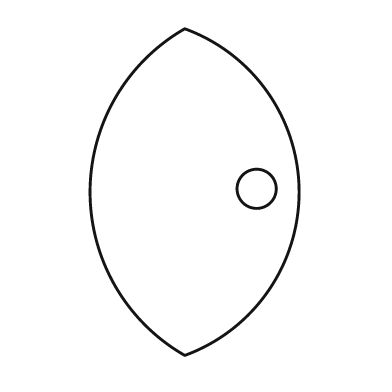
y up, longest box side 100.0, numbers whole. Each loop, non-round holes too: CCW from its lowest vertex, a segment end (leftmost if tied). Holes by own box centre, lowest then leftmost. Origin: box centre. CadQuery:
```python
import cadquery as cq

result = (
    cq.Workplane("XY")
    .moveTo(-3.0, -50.0)
    .threePointArc((32.0, 0.0), (-3.0, 50.0))
    .threePointArc((-32.0, 0.0), (-3.0, -50.0))
    .close()
    .moveTo(19.0, 1.0)
    .circle(6.0)
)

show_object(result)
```